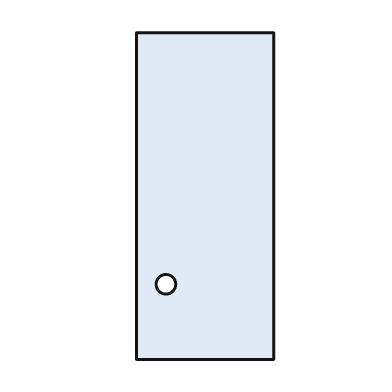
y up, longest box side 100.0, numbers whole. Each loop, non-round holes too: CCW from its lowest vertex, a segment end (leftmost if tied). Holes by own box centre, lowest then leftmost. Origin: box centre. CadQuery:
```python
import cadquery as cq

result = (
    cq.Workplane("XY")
    .moveTo(-21.0, -50.0)
    .lineTo(21.0, -50.0)
    .lineTo(21.0, 50.0)
    .lineTo(-21.0, 50.0)
    .close()
    .moveTo(-12.0, -27.0)
    .circle(3.0)
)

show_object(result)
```